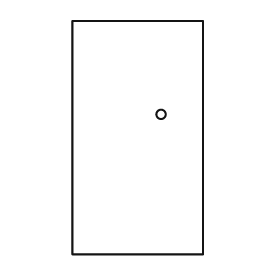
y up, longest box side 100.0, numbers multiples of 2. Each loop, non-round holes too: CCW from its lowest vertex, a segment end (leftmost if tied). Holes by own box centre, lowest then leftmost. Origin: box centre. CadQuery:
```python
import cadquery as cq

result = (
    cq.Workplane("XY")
    .moveTo(-28.0, -50.0)
    .lineTo(28.0, -50.0)
    .lineTo(28.0, 50.0)
    .lineTo(-28.0, 50.0)
    .close()
    .moveTo(10.0, 10.0)
    .circle(2.0)
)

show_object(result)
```